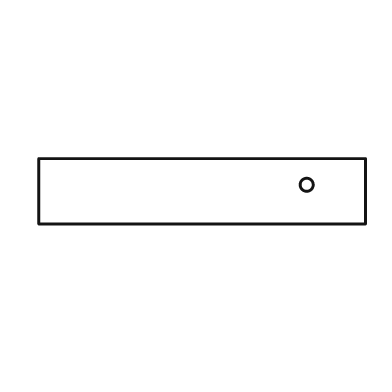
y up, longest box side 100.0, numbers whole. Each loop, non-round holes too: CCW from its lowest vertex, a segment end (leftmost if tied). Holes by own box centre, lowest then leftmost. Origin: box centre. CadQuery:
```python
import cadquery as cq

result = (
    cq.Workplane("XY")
    .moveTo(-50.0, -10.0)
    .lineTo(50.0, -10.0)
    .lineTo(50.0, 10.0)
    .lineTo(-50.0, 10.0)
    .close()
    .moveTo(32.0, 2.0)
    .circle(2.0)
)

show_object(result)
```